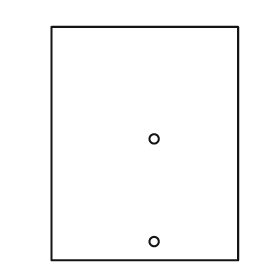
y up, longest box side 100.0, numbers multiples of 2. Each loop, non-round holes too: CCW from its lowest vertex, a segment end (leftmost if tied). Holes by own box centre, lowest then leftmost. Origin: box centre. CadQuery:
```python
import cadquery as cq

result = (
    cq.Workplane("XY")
    .moveTo(-40.0, -50.0)
    .lineTo(40.0, -50.0)
    .lineTo(40.0, 50.0)
    .lineTo(-40.0, 50.0)
    .close()
    .moveTo(4.0, -42.0)
    .circle(2.0)
    .moveTo(4.0, 2.0)
    .circle(2.0)
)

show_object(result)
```